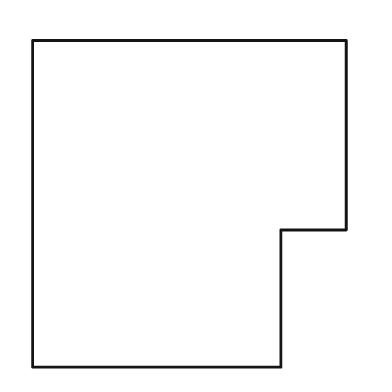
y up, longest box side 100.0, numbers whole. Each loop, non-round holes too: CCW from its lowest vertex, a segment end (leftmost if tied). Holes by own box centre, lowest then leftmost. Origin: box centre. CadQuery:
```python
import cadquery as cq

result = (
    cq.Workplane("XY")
    .moveTo(-48.0, -50.0)
    .lineTo(28.0, -50.0)
    .lineTo(28.0, -8.0)
    .lineTo(48.0, -8.0)
    .lineTo(48.0, 50.0)
    .lineTo(-48.0, 50.0)
    .close()
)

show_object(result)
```